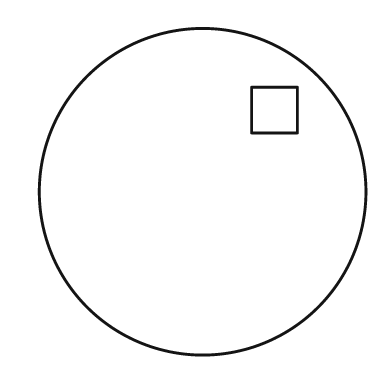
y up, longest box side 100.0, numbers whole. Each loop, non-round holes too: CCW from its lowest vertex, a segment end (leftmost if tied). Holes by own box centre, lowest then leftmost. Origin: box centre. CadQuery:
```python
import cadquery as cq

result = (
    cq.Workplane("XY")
    .moveTo(0.0, 0.0)
    .circle(50.0)
    .moveTo(15.0, 18.0)
    .lineTo(29.0, 18.0)
    .lineTo(29.0, 32.0)
    .lineTo(15.0, 32.0)
    .close()
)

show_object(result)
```